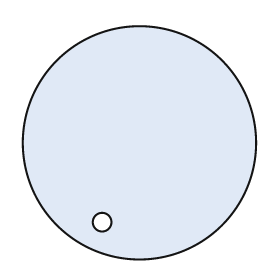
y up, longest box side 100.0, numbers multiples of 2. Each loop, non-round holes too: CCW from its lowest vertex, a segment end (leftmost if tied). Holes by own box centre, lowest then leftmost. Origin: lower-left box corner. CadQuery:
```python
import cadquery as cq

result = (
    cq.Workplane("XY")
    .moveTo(50.0, 50.0)
    .circle(50.0)
    .moveTo(34.0, 16.0)
    .circle(4.0)
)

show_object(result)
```